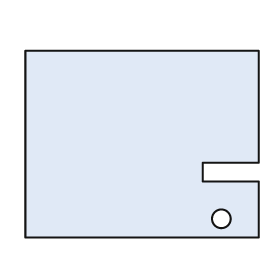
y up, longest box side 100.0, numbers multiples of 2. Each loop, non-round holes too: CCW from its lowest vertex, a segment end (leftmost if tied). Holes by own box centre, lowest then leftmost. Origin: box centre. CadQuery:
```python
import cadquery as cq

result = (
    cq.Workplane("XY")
    .moveTo(-50.0, -40.0)
    .lineTo(50.0, -40.0)
    .lineTo(50.0, -16.0)
    .lineTo(26.0, -16.0)
    .lineTo(26.0, -8.0)
    .lineTo(50.0, -8.0)
    .lineTo(50.0, 40.0)
    .lineTo(-50.0, 40.0)
    .close()
    .moveTo(34.0, -32.0)
    .circle(4.0)
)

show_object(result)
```